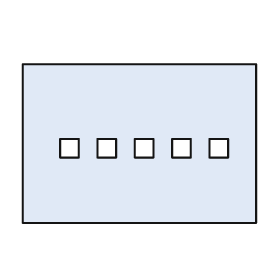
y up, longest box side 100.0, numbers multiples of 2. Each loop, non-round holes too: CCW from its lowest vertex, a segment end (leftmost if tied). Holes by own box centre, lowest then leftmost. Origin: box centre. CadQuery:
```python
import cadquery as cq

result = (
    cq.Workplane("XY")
    .moveTo(-50.0, -34.0)
    .lineTo(50.0, -34.0)
    .lineTo(50.0, 34.0)
    .lineTo(-50.0, 34.0)
    .close()
    .moveTo(-34.0, -6.0)
    .lineTo(-26.0, -6.0)
    .lineTo(-26.0, 2.0)
    .lineTo(-34.0, 2.0)
    .close()
    .moveTo(-18.0, -6.0)
    .lineTo(-10.0, -6.0)
    .lineTo(-10.0, 2.0)
    .lineTo(-18.0, 2.0)
    .close()
    .moveTo(-2.0, -6.0)
    .lineTo(6.0, -6.0)
    .lineTo(6.0, 2.0)
    .lineTo(-2.0, 2.0)
    .close()
    .moveTo(14.0, -6.0)
    .lineTo(22.0, -6.0)
    .lineTo(22.0, 2.0)
    .lineTo(14.0, 2.0)
    .close()
    .moveTo(30.0, -6.0)
    .lineTo(38.0, -6.0)
    .lineTo(38.0, 2.0)
    .lineTo(30.0, 2.0)
    .close()
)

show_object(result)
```